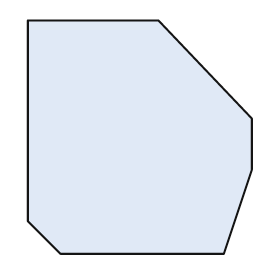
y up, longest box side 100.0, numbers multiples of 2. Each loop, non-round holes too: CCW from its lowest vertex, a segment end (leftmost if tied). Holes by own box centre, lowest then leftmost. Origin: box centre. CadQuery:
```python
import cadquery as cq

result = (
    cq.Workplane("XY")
    .moveTo(-34.0, -50.0)
    .lineTo(36.0, -50.0)
    .lineTo(48.0, -14.0)
    .lineTo(48.0, 8.0)
    .lineTo(8.0, 50.0)
    .lineTo(-48.0, 50.0)
    .lineTo(-48.0, -36.0)
    .close()
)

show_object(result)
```